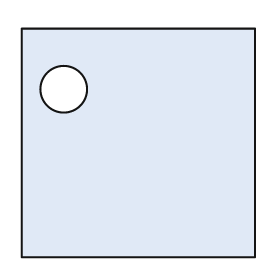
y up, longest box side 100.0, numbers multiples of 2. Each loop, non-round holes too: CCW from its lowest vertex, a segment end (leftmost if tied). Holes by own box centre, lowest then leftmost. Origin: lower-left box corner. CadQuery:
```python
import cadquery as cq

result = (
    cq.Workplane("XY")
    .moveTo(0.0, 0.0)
    .lineTo(100.0, 0.0)
    .lineTo(100.0, 98.0)
    .lineTo(0.0, 98.0)
    .close()
    .moveTo(18.0, 72.0)
    .circle(10.0)
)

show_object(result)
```